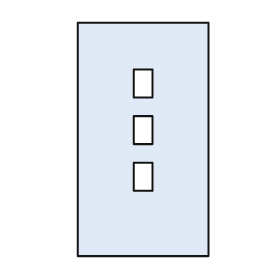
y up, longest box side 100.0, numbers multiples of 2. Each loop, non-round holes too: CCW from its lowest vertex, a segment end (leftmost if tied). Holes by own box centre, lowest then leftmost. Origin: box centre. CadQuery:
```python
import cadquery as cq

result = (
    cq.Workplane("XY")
    .moveTo(-28.0, -50.0)
    .lineTo(28.0, -50.0)
    .lineTo(28.0, 50.0)
    .lineTo(-28.0, 50.0)
    .close()
    .moveTo(-4.0, -22.0)
    .lineTo(4.0, -22.0)
    .lineTo(4.0, -10.0)
    .lineTo(-4.0, -10.0)
    .close()
    .moveTo(-4.0, -2.0)
    .lineTo(4.0, -2.0)
    .lineTo(4.0, 10.0)
    .lineTo(-4.0, 10.0)
    .close()
    .moveTo(-4.0, 18.0)
    .lineTo(4.0, 18.0)
    .lineTo(4.0, 30.0)
    .lineTo(-4.0, 30.0)
    .close()
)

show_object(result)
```